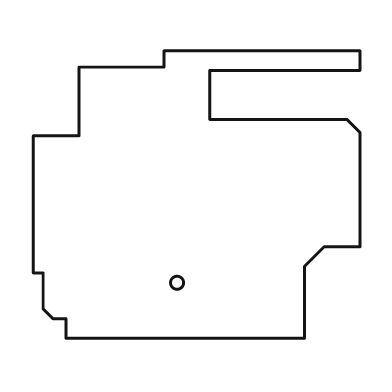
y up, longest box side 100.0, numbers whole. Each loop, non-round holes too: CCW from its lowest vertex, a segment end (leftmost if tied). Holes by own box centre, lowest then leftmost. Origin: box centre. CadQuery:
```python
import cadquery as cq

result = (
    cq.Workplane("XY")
    .moveTo(-40.0, -44.0)
    .lineTo(33.0, -44.0)
    .lineTo(33.0, -22.0)
    .lineTo(39.0, -16.0)
    .lineTo(50.0, -16.0)
    .lineTo(50.0, 19.0)
    .lineTo(46.0, 23.0)
    .lineTo(4.0, 23.0)
    .lineTo(4.0, 38.0)
    .lineTo(50.0, 38.0)
    .lineTo(50.0, 44.0)
    .lineTo(-10.0, 44.0)
    .lineTo(-10.0, 39.0)
    .lineTo(-36.0, 39.0)
    .lineTo(-36.0, 18.0)
    .lineTo(-50.0, 18.0)
    .lineTo(-50.0, -24.0)
    .lineTo(-47.0, -24.0)
    .lineTo(-47.0, -35.0)
    .lineTo(-44.0, -38.0)
    .lineTo(-40.0, -38.0)
    .close()
    .moveTo(-6.0, -27.0)
    .circle(2.0)
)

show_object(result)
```